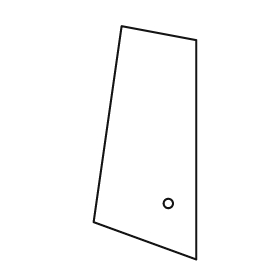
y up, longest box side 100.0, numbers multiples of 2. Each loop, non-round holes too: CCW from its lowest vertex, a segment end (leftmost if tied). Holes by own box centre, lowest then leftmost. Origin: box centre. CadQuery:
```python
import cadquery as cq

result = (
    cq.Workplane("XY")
    .moveTo(22.0, -50.0)
    .lineTo(22.0, 44.0)
    .lineTo(-10.0, 50.0)
    .lineTo(-22.0, -34.0)
    .close()
    .moveTo(10.0, -26.0)
    .circle(2.0)
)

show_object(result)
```